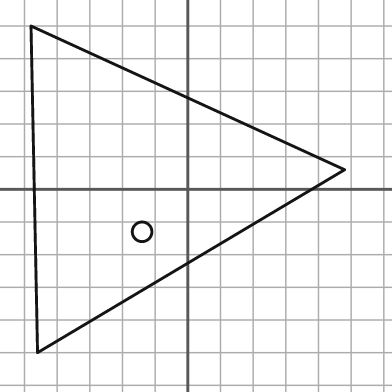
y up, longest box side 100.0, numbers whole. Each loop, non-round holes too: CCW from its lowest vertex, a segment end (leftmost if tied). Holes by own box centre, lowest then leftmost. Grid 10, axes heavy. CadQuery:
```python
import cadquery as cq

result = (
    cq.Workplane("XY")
    .moveTo(-46.0, -50.0)
    .lineTo(48.0, 6.0)
    .lineTo(-48.0, 50.0)
    .close()
    .moveTo(-14.0, -13.0)
    .circle(3.0)
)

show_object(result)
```